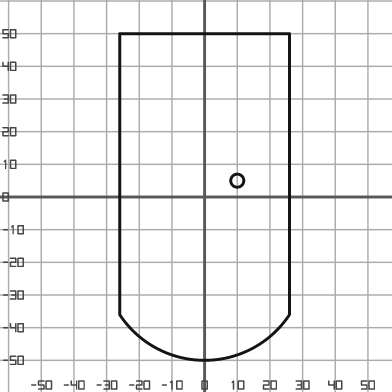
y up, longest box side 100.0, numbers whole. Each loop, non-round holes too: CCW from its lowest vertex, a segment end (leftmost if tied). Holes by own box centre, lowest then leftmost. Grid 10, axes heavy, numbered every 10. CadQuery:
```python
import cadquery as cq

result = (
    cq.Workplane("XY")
    .moveTo(-26.0, -36.0)
    .threePointArc((0.0, -50.0), (26.0, -36.0))
    .lineTo(26.0, 50.0)
    .lineTo(-26.0, 50.0)
    .close()
    .moveTo(10.0, 5.0)
    .circle(2.0)
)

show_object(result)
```